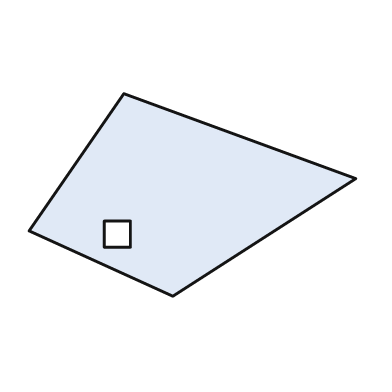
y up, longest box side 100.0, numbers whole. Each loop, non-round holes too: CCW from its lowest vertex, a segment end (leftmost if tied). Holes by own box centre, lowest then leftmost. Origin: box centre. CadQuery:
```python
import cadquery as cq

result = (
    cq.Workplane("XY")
    .moveTo(-6.0, -31.0)
    .lineTo(50.0, 5.0)
    .lineTo(-21.0, 31.0)
    .lineTo(-50.0, -11.0)
    .close()
    .moveTo(-27.0, -16.0)
    .lineTo(-19.0, -16.0)
    .lineTo(-19.0, -8.0)
    .lineTo(-27.0, -8.0)
    .close()
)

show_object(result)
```